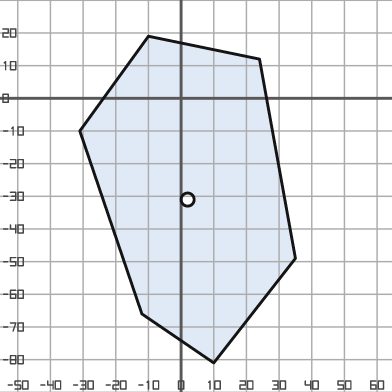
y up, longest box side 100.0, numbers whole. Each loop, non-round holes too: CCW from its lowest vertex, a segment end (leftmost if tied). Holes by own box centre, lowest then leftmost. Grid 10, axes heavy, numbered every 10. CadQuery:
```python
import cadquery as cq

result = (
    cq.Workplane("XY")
    .moveTo(10.0, -81.0)
    .lineTo(35.0, -49.0)
    .lineTo(24.0, 12.0)
    .lineTo(-10.0, 19.0)
    .lineTo(-31.0, -10.0)
    .lineTo(-12.0, -66.0)
    .close()
    .moveTo(2.0, -31.0)
    .circle(2.0)
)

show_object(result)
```